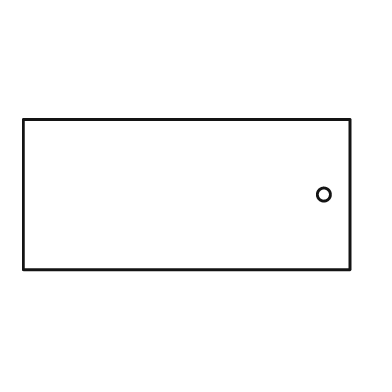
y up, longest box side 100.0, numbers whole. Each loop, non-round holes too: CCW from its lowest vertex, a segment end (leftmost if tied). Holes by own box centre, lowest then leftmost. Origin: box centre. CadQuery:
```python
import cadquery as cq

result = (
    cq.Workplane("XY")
    .moveTo(-50.0, -23.0)
    .lineTo(50.0, -23.0)
    .lineTo(50.0, 23.0)
    .lineTo(-50.0, 23.0)
    .close()
    .moveTo(42.0, 0.0)
    .circle(2.0)
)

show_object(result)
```